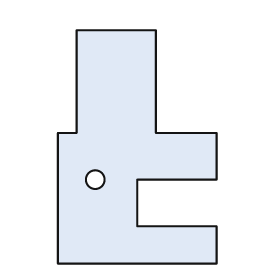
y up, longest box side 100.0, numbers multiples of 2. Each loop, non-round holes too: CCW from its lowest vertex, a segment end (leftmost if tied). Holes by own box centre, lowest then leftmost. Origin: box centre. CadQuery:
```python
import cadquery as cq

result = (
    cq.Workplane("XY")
    .moveTo(-34.0, -50.0)
    .lineTo(34.0, -50.0)
    .lineTo(34.0, -34.0)
    .lineTo(0.0, -34.0)
    .lineTo(0.0, -14.0)
    .lineTo(34.0, -14.0)
    .lineTo(34.0, 6.0)
    .lineTo(8.0, 6.0)
    .lineTo(8.0, 50.0)
    .lineTo(-26.0, 50.0)
    .lineTo(-26.0, 6.0)
    .lineTo(-34.0, 6.0)
    .close()
    .moveTo(-18.0, -14.0)
    .circle(4.0)
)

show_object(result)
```